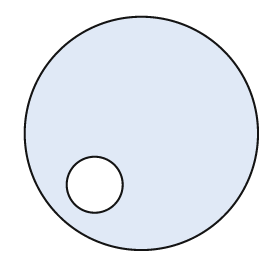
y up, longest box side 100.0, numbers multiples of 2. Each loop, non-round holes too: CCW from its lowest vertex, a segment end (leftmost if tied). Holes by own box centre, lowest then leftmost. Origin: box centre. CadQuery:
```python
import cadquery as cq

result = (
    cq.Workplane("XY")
    .moveTo(0.0, 0.0)
    .circle(50.0)
    .moveTo(-20.0, -22.0)
    .circle(12.0)
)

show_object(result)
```